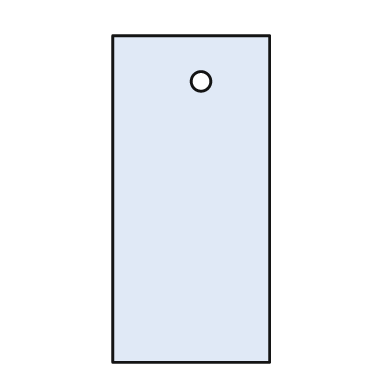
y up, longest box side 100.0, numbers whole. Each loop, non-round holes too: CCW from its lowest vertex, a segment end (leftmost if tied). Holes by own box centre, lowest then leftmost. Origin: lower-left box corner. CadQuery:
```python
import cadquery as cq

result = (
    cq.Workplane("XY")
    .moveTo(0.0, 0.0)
    .lineTo(48.0, 0.0)
    .lineTo(48.0, 100.0)
    .lineTo(0.0, 100.0)
    .close()
    .moveTo(27.0, 86.0)
    .circle(3.0)
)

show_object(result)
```